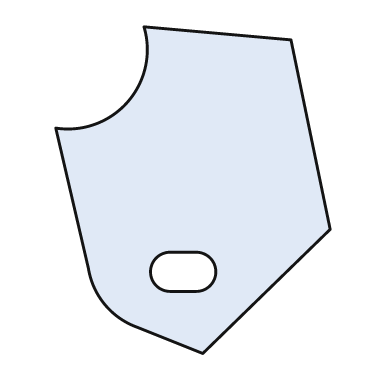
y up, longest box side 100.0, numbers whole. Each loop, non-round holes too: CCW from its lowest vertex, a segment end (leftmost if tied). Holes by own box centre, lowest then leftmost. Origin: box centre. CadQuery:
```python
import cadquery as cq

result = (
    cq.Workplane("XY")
    .moveTo(3.0, -50.0)
    .lineTo(42.0, -12.0)
    .lineTo(30.0, 46.0)
    .lineTo(-15.0, 50.0)
    .threePointArc((-20.0, 27.0), (-42.0, 19.0))
    .lineTo(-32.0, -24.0)
    .threePointArc((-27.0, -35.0), (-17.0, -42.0))
    .close()
    .moveTo(-7.0, -31.0)
    .lineTo(1.0, -31.0)
    .threePointArc((7.0, -25.0), (1.0, -19.0))
    .lineTo(-7.0, -19.0)
    .threePointArc((-13.0, -25.0), (-7.0, -31.0))
    .close()
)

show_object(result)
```